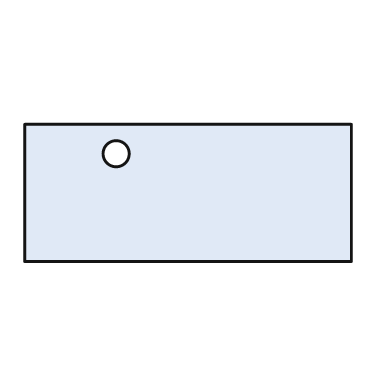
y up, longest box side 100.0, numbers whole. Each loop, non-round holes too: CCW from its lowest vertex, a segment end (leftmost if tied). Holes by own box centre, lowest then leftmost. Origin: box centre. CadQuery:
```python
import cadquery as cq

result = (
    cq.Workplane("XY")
    .moveTo(-50.0, -21.0)
    .lineTo(50.0, -21.0)
    .lineTo(50.0, 21.0)
    .lineTo(-50.0, 21.0)
    .close()
    .moveTo(-22.0, 12.0)
    .circle(4.0)
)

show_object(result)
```